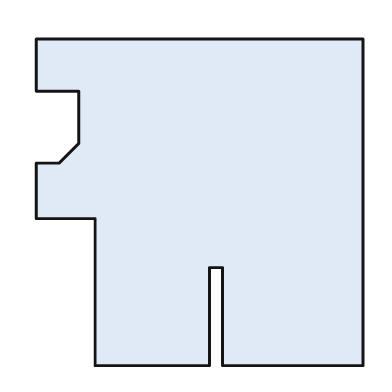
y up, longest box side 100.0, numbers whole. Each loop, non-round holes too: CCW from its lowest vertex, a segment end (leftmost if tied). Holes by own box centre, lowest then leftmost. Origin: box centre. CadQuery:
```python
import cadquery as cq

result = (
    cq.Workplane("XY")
    .moveTo(-32.0, -50.0)
    .lineTo(3.0, -50.0)
    .lineTo(3.0, -20.0)
    .lineTo(7.0, -20.0)
    .lineTo(7.0, -50.0)
    .lineTo(50.0, -50.0)
    .lineTo(50.0, 50.0)
    .lineTo(-50.0, 50.0)
    .lineTo(-50.0, 34.0)
    .lineTo(-37.0, 34.0)
    .lineTo(-37.0, 18.0)
    .lineTo(-43.0, 12.0)
    .lineTo(-50.0, 12.0)
    .lineTo(-50.0, -5.0)
    .lineTo(-32.0, -5.0)
    .close()
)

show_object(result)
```